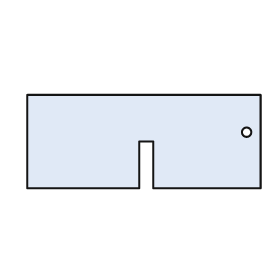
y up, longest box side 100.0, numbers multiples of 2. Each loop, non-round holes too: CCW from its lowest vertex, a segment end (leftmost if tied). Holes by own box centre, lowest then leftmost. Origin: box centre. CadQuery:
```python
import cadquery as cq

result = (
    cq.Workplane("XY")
    .moveTo(-50.0, -20.0)
    .lineTo(-2.0, -20.0)
    .lineTo(-2.0, 0.0)
    .lineTo(4.0, 0.0)
    .lineTo(4.0, -20.0)
    .lineTo(50.0, -20.0)
    .lineTo(50.0, 20.0)
    .lineTo(-50.0, 20.0)
    .close()
    .moveTo(44.0, 4.0)
    .circle(2.0)
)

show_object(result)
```